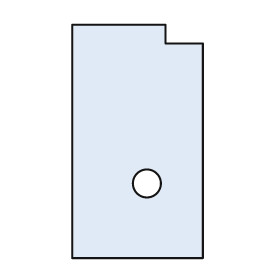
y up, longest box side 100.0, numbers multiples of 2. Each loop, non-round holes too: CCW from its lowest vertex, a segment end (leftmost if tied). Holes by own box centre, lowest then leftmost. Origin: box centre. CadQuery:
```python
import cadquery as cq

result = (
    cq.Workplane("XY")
    .moveTo(-28.0, -50.0)
    .lineTo(28.0, -50.0)
    .lineTo(28.0, 42.0)
    .lineTo(12.0, 42.0)
    .lineTo(12.0, 50.0)
    .lineTo(-28.0, 50.0)
    .close()
    .moveTo(4.0, -18.0)
    .circle(6.0)
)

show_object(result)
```